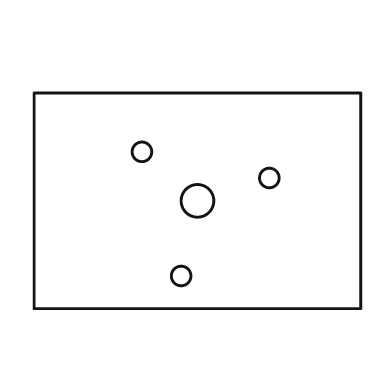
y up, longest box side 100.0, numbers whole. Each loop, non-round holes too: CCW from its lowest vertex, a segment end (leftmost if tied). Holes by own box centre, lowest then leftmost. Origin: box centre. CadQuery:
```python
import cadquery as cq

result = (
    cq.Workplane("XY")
    .moveTo(-50.0, -33.0)
    .lineTo(50.0, -33.0)
    .lineTo(50.0, 33.0)
    .lineTo(-50.0, 33.0)
    .close()
    .moveTo(-5.0, -23.0)
    .circle(3.0)
    .moveTo(0.0, 0.0)
    .circle(5.0)
    .moveTo(22.0, 7.0)
    .circle(3.0)
    .moveTo(-17.0, 15.0)
    .circle(3.0)
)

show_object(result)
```